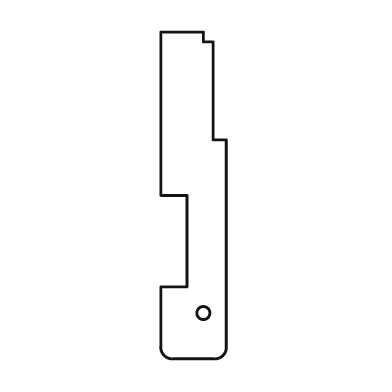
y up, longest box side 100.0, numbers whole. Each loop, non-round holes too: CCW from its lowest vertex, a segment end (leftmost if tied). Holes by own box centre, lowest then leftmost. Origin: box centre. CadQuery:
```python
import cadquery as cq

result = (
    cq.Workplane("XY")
    .moveTo(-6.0, -50.0)
    .lineTo(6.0, -50.0)
    .threePointArc((9.0, -49.0), (10.0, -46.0))
    .lineTo(10.0, 17.0)
    .lineTo(6.0, 17.0)
    .lineTo(6.0, 47.0)
    .lineTo(3.0, 47.0)
    .lineTo(3.0, 50.0)
    .lineTo(-10.0, 50.0)
    .lineTo(-10.0, 0.0)
    .lineTo(-2.0, 0.0)
    .lineTo(-2.0, -28.0)
    .lineTo(-10.0, -28.0)
    .lineTo(-10.0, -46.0)
    .threePointArc((-9.0, -49.0), (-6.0, -50.0))
    .close()
    .moveTo(3.0, -36.0)
    .circle(2.0)
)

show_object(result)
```